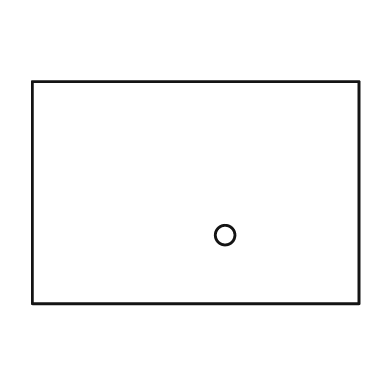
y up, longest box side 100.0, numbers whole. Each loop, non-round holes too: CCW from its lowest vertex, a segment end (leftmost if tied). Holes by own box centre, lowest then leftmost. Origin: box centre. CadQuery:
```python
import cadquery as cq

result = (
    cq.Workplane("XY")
    .moveTo(-50.0, -34.0)
    .lineTo(50.0, -34.0)
    .lineTo(50.0, 34.0)
    .lineTo(-50.0, 34.0)
    .close()
    .moveTo(9.0, -13.0)
    .circle(3.0)
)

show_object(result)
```